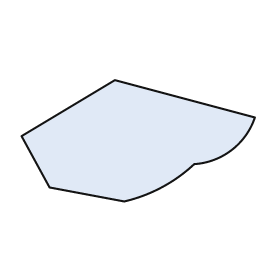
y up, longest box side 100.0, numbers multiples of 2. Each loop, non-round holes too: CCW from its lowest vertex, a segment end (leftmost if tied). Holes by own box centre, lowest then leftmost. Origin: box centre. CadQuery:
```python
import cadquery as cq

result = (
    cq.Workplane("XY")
    .moveTo(-6.0, -26.0)
    .threePointArc((10.0, -20.0), (24.0, -10.0))
    .threePointArc((40.0, -4.0), (50.0, 10.0))
    .lineTo(-10.0, 26.0)
    .lineTo(-50.0, 2.0)
    .lineTo(-38.0, -20.0)
    .close()
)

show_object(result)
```